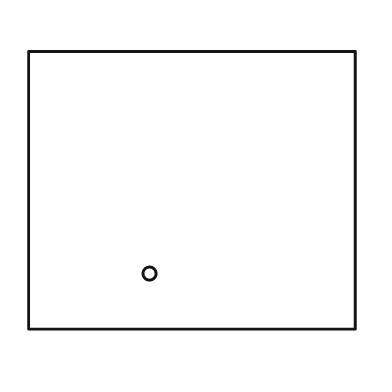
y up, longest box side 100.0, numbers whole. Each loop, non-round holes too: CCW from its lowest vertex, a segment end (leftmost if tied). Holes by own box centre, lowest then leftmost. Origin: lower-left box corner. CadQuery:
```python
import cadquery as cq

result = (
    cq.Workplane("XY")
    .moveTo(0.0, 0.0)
    .lineTo(100.0, 0.0)
    .lineTo(100.0, 85.0)
    .lineTo(0.0, 85.0)
    .close()
    .moveTo(37.0, 17.0)
    .circle(2.0)
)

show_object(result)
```